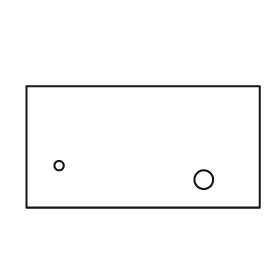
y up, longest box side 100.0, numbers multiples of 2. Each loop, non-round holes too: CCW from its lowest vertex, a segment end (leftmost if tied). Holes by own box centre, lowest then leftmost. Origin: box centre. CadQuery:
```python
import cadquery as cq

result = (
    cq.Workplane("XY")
    .moveTo(-50.0, -26.0)
    .lineTo(50.0, -26.0)
    .lineTo(50.0, 26.0)
    .lineTo(-50.0, 26.0)
    .close()
    .moveTo(26.0, -14.0)
    .circle(4.0)
    .moveTo(-36.0, -8.0)
    .circle(2.0)
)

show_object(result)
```